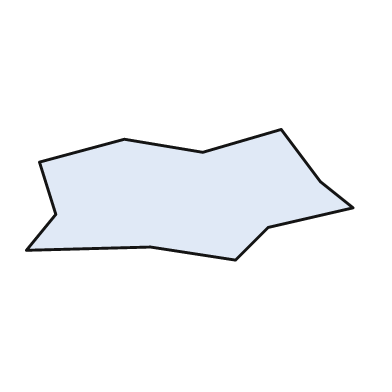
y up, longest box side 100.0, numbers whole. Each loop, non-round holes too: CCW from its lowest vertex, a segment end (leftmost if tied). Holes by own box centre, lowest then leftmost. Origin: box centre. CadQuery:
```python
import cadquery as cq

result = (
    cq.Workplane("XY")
    .moveTo(14.0, -20.0)
    .lineTo(24.0, -10.0)
    .lineTo(50.0, -4.0)
    .lineTo(40.0, 4.0)
    .lineTo(28.0, 20.0)
    .lineTo(4.0, 13.0)
    .lineTo(-20.0, 17.0)
    .lineTo(-46.0, 10.0)
    .lineTo(-41.0, -6.0)
    .lineTo(-50.0, -17.0)
    .lineTo(-12.0, -16.0)
    .close()
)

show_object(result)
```